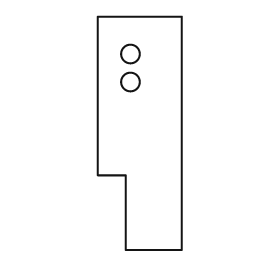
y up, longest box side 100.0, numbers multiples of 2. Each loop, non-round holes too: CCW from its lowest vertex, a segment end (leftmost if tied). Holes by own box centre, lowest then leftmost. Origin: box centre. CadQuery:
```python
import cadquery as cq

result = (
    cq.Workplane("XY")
    .moveTo(-6.0, -50.0)
    .lineTo(18.0, -50.0)
    .lineTo(18.0, 50.0)
    .lineTo(-18.0, 50.0)
    .lineTo(-18.0, -18.0)
    .lineTo(-6.0, -18.0)
    .close()
    .moveTo(-4.0, 22.0)
    .circle(4.0)
    .moveTo(-4.0, 34.0)
    .circle(4.0)
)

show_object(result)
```